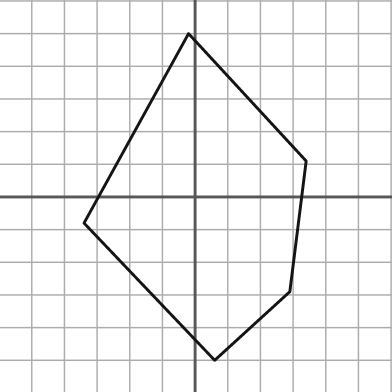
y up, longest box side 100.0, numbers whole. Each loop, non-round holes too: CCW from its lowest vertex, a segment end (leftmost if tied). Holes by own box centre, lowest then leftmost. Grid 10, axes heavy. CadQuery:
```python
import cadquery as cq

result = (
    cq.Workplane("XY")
    .moveTo(6.0, -50.0)
    .lineTo(29.0, -29.0)
    .lineTo(34.0, 11.0)
    .lineTo(-2.0, 50.0)
    .lineTo(-34.0, -8.0)
    .close()
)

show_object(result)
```